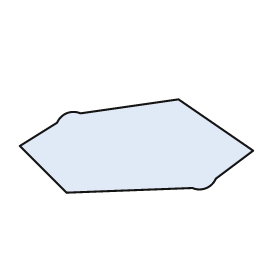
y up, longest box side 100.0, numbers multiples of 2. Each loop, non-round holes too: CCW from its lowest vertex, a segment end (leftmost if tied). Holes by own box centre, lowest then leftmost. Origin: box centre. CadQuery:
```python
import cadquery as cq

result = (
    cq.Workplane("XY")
    .moveTo(-30.0, -20.0)
    .lineTo(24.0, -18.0)
    .threePointArc((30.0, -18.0), (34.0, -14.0))
    .lineTo(50.0, -2.0)
    .lineTo(18.0, 20.0)
    .lineTo(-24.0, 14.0)
    .threePointArc((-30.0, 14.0), (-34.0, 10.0))
    .lineTo(-50.0, 0.0)
    .close()
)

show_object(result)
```